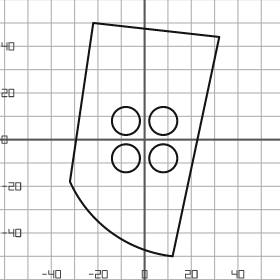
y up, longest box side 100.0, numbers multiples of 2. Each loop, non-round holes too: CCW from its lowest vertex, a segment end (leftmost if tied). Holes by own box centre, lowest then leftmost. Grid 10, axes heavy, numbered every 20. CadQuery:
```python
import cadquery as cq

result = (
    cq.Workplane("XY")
    .moveTo(12.0, -50.0)
    .lineTo(32.0, 44.0)
    .lineTo(-22.0, 50.0)
    .lineTo(-32.0, -18.0)
    .threePointArc((-14.0, -40.0), (12.0, -50.0))
    .close()
    .moveTo(-8.0, -8.0)
    .circle(6.0)
    .moveTo(8.0, -8.0)
    .circle(6.0)
    .moveTo(-8.0, 8.0)
    .circle(6.0)
    .moveTo(8.0, 8.0)
    .circle(6.0)
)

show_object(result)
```